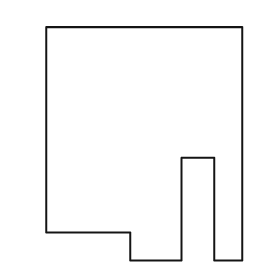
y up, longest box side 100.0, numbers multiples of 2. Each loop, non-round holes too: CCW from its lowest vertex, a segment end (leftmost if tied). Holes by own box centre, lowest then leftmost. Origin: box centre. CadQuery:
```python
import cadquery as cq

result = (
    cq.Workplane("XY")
    .moveTo(-6.0, -50.0)
    .lineTo(16.0, -50.0)
    .lineTo(16.0, -6.0)
    .lineTo(30.0, -6.0)
    .lineTo(30.0, -50.0)
    .lineTo(42.0, -50.0)
    .lineTo(42.0, 50.0)
    .lineTo(-42.0, 50.0)
    .lineTo(-42.0, -38.0)
    .lineTo(-6.0, -38.0)
    .close()
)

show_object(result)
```